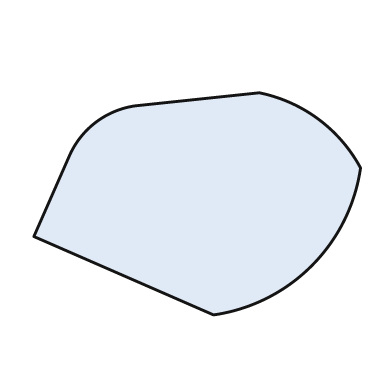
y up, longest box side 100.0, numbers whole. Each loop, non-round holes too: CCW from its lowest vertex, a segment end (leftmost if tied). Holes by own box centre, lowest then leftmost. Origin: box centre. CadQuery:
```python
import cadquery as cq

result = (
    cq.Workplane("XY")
    .moveTo(5.0, -34.0)
    .threePointArc((35.0, -19.0), (50.0, 11.0))
    .threePointArc((37.0, 26.0), (19.0, 34.0))
    .lineTo(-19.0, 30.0)
    .threePointArc((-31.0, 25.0), (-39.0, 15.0))
    .lineTo(-50.0, -10.0)
    .close()
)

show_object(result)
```